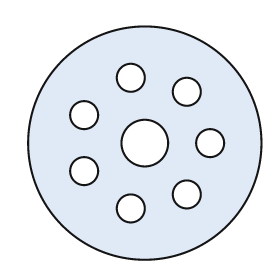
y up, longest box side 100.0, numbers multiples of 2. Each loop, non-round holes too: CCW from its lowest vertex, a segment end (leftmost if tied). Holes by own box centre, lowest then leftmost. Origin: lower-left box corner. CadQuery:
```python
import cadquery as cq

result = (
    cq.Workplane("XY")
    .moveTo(50.0, 50.0)
    .circle(50.0)
    .moveTo(44.0, 22.0)
    .circle(6.0)
    .moveTo(68.0, 28.0)
    .circle(6.0)
    .moveTo(24.0, 38.0)
    .circle(6.0)
    .moveTo(50.0, 50.0)
    .circle(10.0)
    .moveTo(78.0, 50.0)
    .circle(6.0)
    .moveTo(24.0, 62.0)
    .circle(6.0)
    .moveTo(68.0, 72.0)
    .circle(6.0)
    .moveTo(44.0, 78.0)
    .circle(6.0)
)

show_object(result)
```